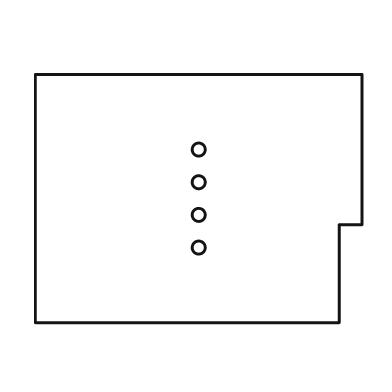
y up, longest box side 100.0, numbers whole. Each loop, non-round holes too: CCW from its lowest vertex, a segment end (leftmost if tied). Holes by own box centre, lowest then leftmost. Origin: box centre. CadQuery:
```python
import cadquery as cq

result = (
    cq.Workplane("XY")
    .moveTo(-50.0, -38.0)
    .lineTo(43.0, -38.0)
    .lineTo(43.0, -8.0)
    .lineTo(50.0, -8.0)
    .lineTo(50.0, 38.0)
    .lineTo(-50.0, 38.0)
    .close()
    .moveTo(0.0, -15.0)
    .circle(2.0)
    .moveTo(0.0, -5.0)
    .circle(2.0)
    .moveTo(0.0, 5.0)
    .circle(2.0)
    .moveTo(0.0, 15.0)
    .circle(2.0)
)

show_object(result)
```